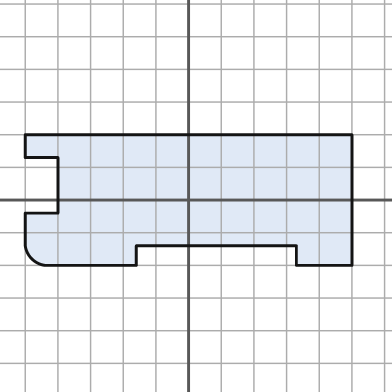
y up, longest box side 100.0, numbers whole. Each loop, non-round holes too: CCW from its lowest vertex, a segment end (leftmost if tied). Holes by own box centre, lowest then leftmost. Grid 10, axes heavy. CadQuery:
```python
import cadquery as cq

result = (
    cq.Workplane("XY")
    .moveTo(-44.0, -20.0)
    .lineTo(-16.0, -20.0)
    .lineTo(-16.0, -14.0)
    .lineTo(33.0, -14.0)
    .lineTo(33.0, -20.0)
    .lineTo(50.0, -20.0)
    .lineTo(50.0, 20.0)
    .lineTo(-50.0, 20.0)
    .lineTo(-50.0, 13.0)
    .lineTo(-40.0, 13.0)
    .lineTo(-40.0, -4.0)
    .lineTo(-50.0, -4.0)
    .lineTo(-50.0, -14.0)
    .threePointArc((-48.0, -18.0), (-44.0, -20.0))
    .close()
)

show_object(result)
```